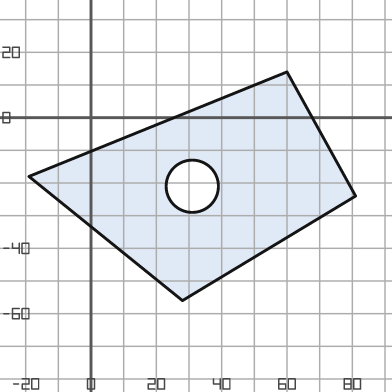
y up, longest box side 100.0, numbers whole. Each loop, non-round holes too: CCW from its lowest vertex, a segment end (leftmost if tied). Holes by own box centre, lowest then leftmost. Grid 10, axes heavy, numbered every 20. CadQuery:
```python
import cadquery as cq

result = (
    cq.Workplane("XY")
    .moveTo(28.0, -56.0)
    .lineTo(81.0, -24.0)
    .lineTo(60.0, 14.0)
    .lineTo(-19.0, -18.0)
    .close()
    .moveTo(31.0, -21.0)
    .circle(8.0)
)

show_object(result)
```